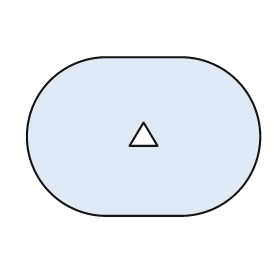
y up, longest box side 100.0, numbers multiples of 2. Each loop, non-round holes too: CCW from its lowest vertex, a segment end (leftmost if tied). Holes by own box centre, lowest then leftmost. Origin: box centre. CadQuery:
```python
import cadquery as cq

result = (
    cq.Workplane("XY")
    .moveTo(-16.0, -34.0)
    .lineTo(16.0, -34.0)
    .threePointArc((50.0, 0.0), (16.0, 34.0))
    .lineTo(-16.0, 34.0)
    .threePointArc((-50.0, 0.0), (-16.0, -34.0))
    .close()
    .moveTo(-6.0, -4.0)
    .lineTo(6.0, -4.0)
    .lineTo(0.0, 6.0)
    .close()
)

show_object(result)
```